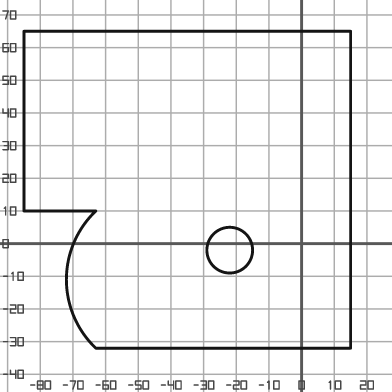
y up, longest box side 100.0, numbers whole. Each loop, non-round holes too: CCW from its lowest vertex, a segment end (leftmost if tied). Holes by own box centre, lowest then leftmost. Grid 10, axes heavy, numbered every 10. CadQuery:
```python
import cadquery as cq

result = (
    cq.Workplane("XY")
    .moveTo(-63.0, -32.0)
    .lineTo(15.0, -32.0)
    .lineTo(15.0, 65.0)
    .lineTo(-85.0, 65.0)
    .lineTo(-85.0, 10.0)
    .lineTo(-63.0, 10.0)
    .threePointArc((-72.0, -11.0), (-63.0, -32.0))
    .close()
    .moveTo(-22.0, -2.0)
    .circle(7.0)
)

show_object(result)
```